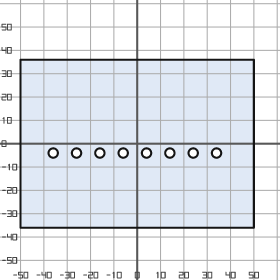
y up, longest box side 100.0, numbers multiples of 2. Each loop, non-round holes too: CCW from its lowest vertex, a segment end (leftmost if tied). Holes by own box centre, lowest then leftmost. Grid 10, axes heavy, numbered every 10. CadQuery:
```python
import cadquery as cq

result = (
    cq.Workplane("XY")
    .moveTo(-50.0, -36.0)
    .lineTo(50.0, -36.0)
    .lineTo(50.0, 36.0)
    .lineTo(-50.0, 36.0)
    .close()
    .moveTo(-36.0, -4.0)
    .circle(2.0)
    .moveTo(-26.0, -4.0)
    .circle(2.0)
    .moveTo(-16.0, -4.0)
    .circle(2.0)
    .moveTo(-6.0, -4.0)
    .circle(2.0)
    .moveTo(4.0, -4.0)
    .circle(2.0)
    .moveTo(14.0, -4.0)
    .circle(2.0)
    .moveTo(24.0, -4.0)
    .circle(2.0)
    .moveTo(34.0, -4.0)
    .circle(2.0)
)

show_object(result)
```